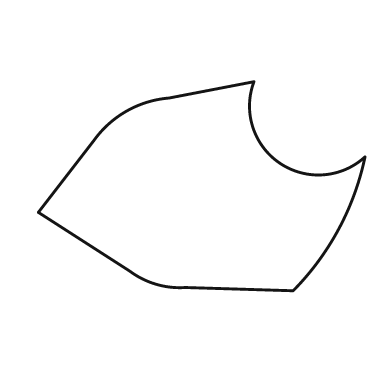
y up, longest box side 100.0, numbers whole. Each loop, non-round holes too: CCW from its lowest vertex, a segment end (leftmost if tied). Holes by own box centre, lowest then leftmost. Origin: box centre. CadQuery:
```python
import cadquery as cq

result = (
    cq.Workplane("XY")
    .moveTo(28.0, -32.0)
    .threePointArc((42.0, -13.0), (50.0, 9.0))
    .threePointArc((24.0, 7.0), (16.0, 32.0))
    .lineTo(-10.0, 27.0)
    .threePointArc((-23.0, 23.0), (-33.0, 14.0))
    .lineTo(-50.0, -8.0)
    .lineTo(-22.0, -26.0)
    .threePointArc((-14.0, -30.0), (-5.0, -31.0))
    .close()
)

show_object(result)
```